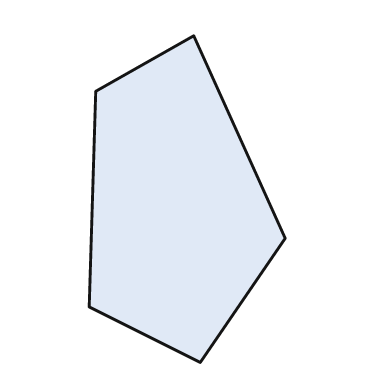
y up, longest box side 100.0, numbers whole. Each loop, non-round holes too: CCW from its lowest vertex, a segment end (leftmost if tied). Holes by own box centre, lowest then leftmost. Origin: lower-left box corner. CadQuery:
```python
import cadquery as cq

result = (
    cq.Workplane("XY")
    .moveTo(34.0, 0.0)
    .lineTo(60.0, 38.0)
    .lineTo(32.0, 100.0)
    .lineTo(2.0, 83.0)
    .lineTo(0.0, 17.0)
    .close()
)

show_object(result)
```